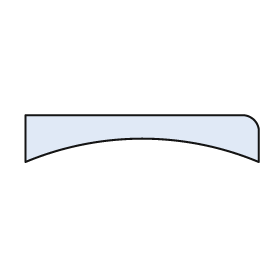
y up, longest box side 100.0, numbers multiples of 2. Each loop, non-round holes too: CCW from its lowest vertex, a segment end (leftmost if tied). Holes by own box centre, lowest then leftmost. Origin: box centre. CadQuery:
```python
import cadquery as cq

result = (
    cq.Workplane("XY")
    .moveTo(-50.0, -10.0)
    .threePointArc((0.0, 0.0), (50.0, -10.0))
    .lineTo(50.0, 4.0)
    .threePointArc((48.0, 8.0), (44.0, 10.0))
    .lineTo(-50.0, 10.0)
    .close()
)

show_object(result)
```